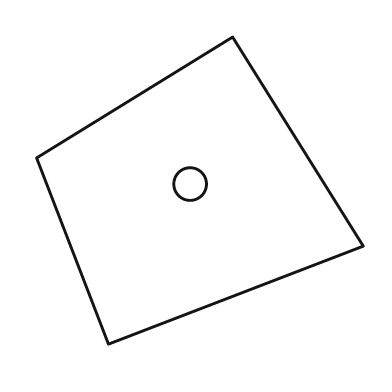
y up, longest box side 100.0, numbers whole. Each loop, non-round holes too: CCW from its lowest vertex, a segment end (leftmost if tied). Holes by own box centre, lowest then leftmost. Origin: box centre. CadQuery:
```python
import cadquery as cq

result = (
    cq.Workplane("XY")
    .moveTo(-28.0, -47.0)
    .lineTo(50.0, -17.0)
    .lineTo(10.0, 47.0)
    .lineTo(-50.0, 10.0)
    .close()
    .moveTo(-3.0, 2.0)
    .circle(5.0)
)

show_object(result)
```